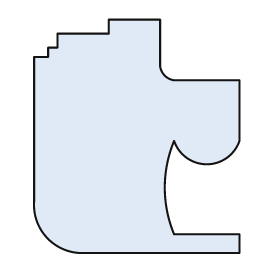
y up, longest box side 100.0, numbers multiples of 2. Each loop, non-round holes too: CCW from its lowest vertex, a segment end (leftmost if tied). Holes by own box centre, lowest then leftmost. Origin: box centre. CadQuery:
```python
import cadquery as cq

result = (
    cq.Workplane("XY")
    .moveTo(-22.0, -50.0)
    .lineTo(44.0, -50.0)
    .lineTo(44.0, -42.0)
    .lineTo(16.0, -42.0)
    .threePointArc((12.0, -22.0), (16.0, -2.0))
    .threePointArc((30.0, -12.0), (44.0, -2.0))
    .lineTo(44.0, 24.0)
    .lineTo(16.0, 24.0)
    .threePointArc((12.0, 26.0), (10.0, 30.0))
    .lineTo(10.0, 50.0)
    .lineTo(-12.0, 50.0)
    .lineTo(-12.0, 44.0)
    .lineTo(-34.0, 44.0)
    .lineTo(-34.0, 38.0)
    .lineTo(-38.0, 38.0)
    .lineTo(-38.0, 34.0)
    .lineTo(-44.0, 34.0)
    .lineTo(-44.0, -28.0)
    .threePointArc((-38.0, -44.0), (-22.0, -50.0))
    .close()
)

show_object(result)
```